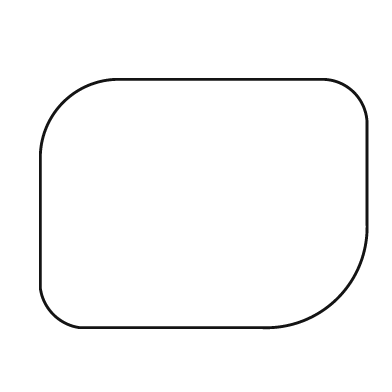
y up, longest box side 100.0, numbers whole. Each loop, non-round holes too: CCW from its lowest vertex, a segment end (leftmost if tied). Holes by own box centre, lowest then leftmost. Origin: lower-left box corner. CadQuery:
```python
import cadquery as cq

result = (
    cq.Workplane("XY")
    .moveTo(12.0, 0.0)
    .lineTo(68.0, 0.0)
    .threePointArc((91.0, 9.0), (100.0, 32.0))
    .lineTo(100.0, 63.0)
    .threePointArc((96.0, 72.0), (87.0, 76.0))
    .lineTo(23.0, 76.0)
    .threePointArc((7.0, 69.0), (0.0, 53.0))
    .lineTo(0.0, 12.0)
    .threePointArc((4.0, 4.0), (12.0, 0.0))
    .close()
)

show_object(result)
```